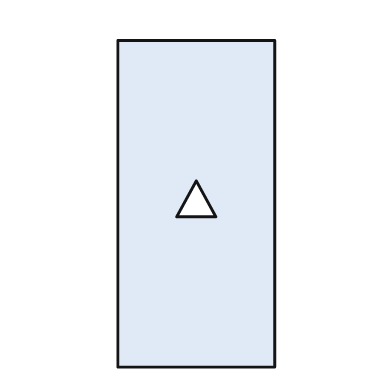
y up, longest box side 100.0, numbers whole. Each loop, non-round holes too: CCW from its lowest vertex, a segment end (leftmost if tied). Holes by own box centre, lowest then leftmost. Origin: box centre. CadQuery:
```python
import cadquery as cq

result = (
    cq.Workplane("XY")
    .moveTo(-24.0, -50.0)
    .lineTo(24.0, -50.0)
    .lineTo(24.0, 50.0)
    .lineTo(-24.0, 50.0)
    .close()
    .moveTo(-6.0, -4.0)
    .lineTo(6.0, -4.0)
    .lineTo(0.0, 7.0)
    .close()
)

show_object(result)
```